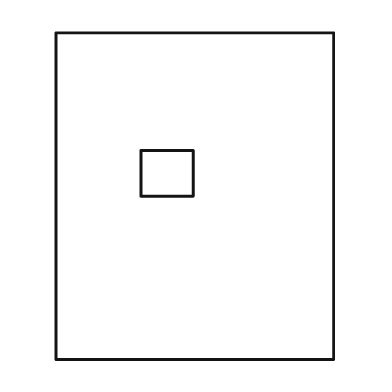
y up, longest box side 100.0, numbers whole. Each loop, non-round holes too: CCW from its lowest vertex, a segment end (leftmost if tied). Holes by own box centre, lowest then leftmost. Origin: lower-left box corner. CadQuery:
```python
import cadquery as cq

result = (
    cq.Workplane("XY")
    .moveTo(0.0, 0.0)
    .lineTo(85.0, 0.0)
    .lineTo(85.0, 100.0)
    .lineTo(0.0, 100.0)
    .close()
    .moveTo(26.0, 50.0)
    .lineTo(42.0, 50.0)
    .lineTo(42.0, 64.0)
    .lineTo(26.0, 64.0)
    .close()
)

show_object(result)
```